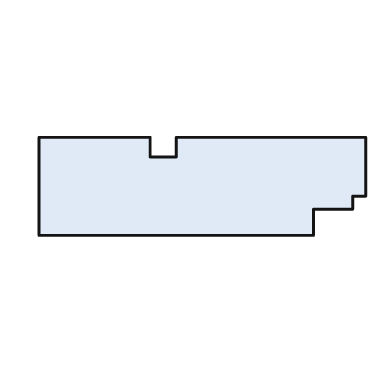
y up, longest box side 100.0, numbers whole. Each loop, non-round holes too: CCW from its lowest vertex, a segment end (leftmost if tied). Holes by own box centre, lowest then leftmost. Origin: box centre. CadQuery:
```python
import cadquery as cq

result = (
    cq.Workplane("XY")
    .moveTo(-50.0, -15.0)
    .lineTo(34.0, -15.0)
    .lineTo(34.0, -7.0)
    .lineTo(46.0, -7.0)
    .lineTo(46.0, -3.0)
    .lineTo(50.0, -3.0)
    .lineTo(50.0, 15.0)
    .lineTo(-8.0, 15.0)
    .lineTo(-8.0, 9.0)
    .lineTo(-16.0, 9.0)
    .lineTo(-16.0, 15.0)
    .lineTo(-50.0, 15.0)
    .close()
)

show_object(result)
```